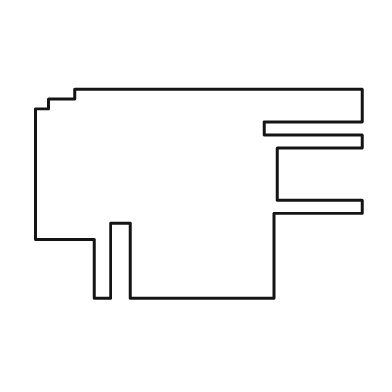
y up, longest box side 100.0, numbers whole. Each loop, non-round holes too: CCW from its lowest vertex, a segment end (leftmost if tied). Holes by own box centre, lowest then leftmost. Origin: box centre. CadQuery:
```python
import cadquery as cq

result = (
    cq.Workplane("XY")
    .moveTo(-32.0, -32.0)
    .lineTo(-27.0, -32.0)
    .lineTo(-27.0, -9.0)
    .lineTo(-21.0, -9.0)
    .lineTo(-21.0, -32.0)
    .lineTo(23.0, -32.0)
    .lineTo(23.0, -6.0)
    .lineTo(50.0, -6.0)
    .lineTo(50.0, -2.0)
    .lineTo(24.0, -2.0)
    .lineTo(24.0, 14.0)
    .lineTo(50.0, 14.0)
    .lineTo(50.0, 18.0)
    .lineTo(20.0, 18.0)
    .lineTo(20.0, 22.0)
    .lineTo(50.0, 22.0)
    .lineTo(50.0, 32.0)
    .lineTo(-38.0, 32.0)
    .lineTo(-38.0, 29.0)
    .lineTo(-46.0, 29.0)
    .lineTo(-46.0, 26.0)
    .lineTo(-50.0, 26.0)
    .lineTo(-50.0, -14.0)
    .lineTo(-32.0, -14.0)
    .close()
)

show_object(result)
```